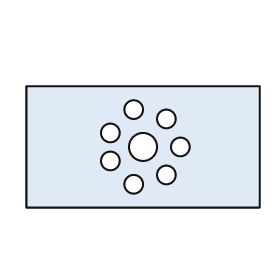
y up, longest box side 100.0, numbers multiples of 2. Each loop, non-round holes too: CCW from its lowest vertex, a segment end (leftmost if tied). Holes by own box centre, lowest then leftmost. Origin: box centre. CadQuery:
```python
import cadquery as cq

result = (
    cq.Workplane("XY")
    .moveTo(-50.0, -26.0)
    .lineTo(50.0, -26.0)
    .lineTo(50.0, 26.0)
    .lineTo(-50.0, 26.0)
    .close()
    .moveTo(-4.0, -16.0)
    .circle(4.0)
    .moveTo(10.0, -12.0)
    .circle(4.0)
    .moveTo(-14.0, -6.0)
    .circle(4.0)
    .moveTo(0.0, 0.0)
    .circle(6.0)
    .moveTo(16.0, 0.0)
    .circle(4.0)
    .moveTo(-14.0, 6.0)
    .circle(4.0)
    .moveTo(10.0, 12.0)
    .circle(4.0)
    .moveTo(-4.0, 16.0)
    .circle(4.0)
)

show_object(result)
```